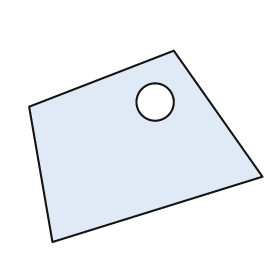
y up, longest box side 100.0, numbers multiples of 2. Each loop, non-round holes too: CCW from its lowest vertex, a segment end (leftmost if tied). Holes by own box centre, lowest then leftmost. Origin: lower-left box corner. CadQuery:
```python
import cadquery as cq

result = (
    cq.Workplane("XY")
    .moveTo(10.0, 0.0)
    .lineTo(100.0, 28.0)
    .lineTo(62.0, 82.0)
    .lineTo(0.0, 58.0)
    .close()
    .moveTo(54.0, 60.0)
    .circle(8.0)
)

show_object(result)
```